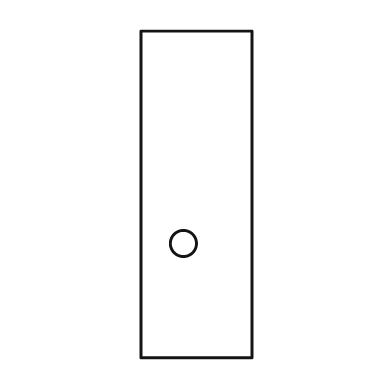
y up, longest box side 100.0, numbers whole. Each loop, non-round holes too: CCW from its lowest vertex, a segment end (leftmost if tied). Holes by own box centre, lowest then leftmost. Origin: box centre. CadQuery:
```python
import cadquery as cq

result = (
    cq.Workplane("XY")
    .moveTo(-17.0, -50.0)
    .lineTo(17.0, -50.0)
    .lineTo(17.0, 50.0)
    .lineTo(-17.0, 50.0)
    .close()
    .moveTo(-4.0, -15.0)
    .circle(4.0)
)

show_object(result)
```